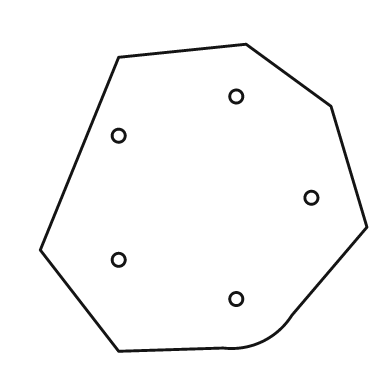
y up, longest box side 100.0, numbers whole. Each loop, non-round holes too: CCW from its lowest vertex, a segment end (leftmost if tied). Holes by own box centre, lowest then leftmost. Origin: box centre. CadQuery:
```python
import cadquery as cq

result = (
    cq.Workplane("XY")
    .moveTo(-26.0, -47.0)
    .lineTo(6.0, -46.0)
    .threePointArc((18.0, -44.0), (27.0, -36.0))
    .lineTo(50.0, -9.0)
    .lineTo(39.0, 28.0)
    .lineTo(13.0, 47.0)
    .lineTo(-26.0, 43.0)
    .lineTo(-50.0, -16.0)
    .close()
    .moveTo(10.0, -31.0)
    .circle(2.0)
    .moveTo(-26.0, -19.0)
    .circle(2.0)
    .moveTo(33.0, 0.0)
    .circle(2.0)
    .moveTo(-26.0, 19.0)
    .circle(2.0)
    .moveTo(10.0, 31.0)
    .circle(2.0)
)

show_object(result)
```